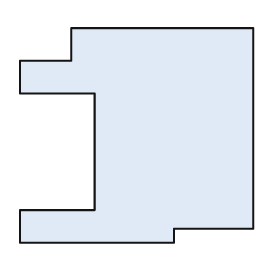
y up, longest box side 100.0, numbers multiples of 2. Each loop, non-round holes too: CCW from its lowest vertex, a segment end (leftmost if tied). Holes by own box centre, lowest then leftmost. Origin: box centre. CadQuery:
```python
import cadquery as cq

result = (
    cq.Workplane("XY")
    .moveTo(-50.0, -46.0)
    .lineTo(16.0, -46.0)
    .lineTo(16.0, -40.0)
    .lineTo(50.0, -40.0)
    .lineTo(50.0, 46.0)
    .lineTo(-28.0, 46.0)
    .lineTo(-28.0, 32.0)
    .lineTo(-50.0, 32.0)
    .lineTo(-50.0, 18.0)
    .lineTo(-18.0, 18.0)
    .lineTo(-18.0, -32.0)
    .lineTo(-50.0, -32.0)
    .close()
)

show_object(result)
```